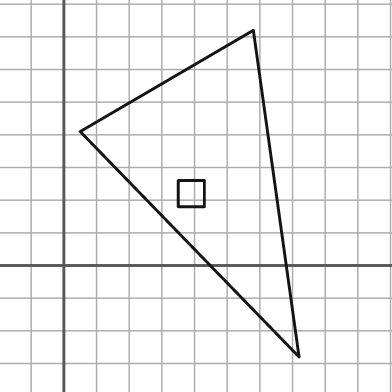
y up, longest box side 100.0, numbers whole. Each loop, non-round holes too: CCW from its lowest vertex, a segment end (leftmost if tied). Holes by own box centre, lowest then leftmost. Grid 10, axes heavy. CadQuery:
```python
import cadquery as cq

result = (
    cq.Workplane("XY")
    .moveTo(72.0, -28.0)
    .lineTo(58.0, 72.0)
    .lineTo(5.0, 41.0)
    .close()
    .moveTo(35.0, 18.0)
    .lineTo(43.0, 18.0)
    .lineTo(43.0, 26.0)
    .lineTo(35.0, 26.0)
    .close()
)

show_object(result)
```